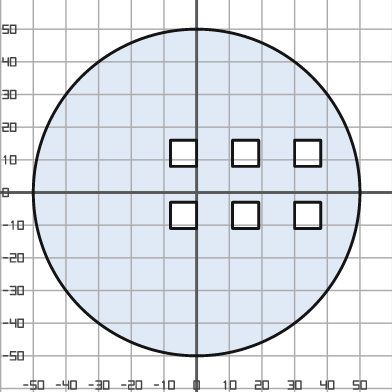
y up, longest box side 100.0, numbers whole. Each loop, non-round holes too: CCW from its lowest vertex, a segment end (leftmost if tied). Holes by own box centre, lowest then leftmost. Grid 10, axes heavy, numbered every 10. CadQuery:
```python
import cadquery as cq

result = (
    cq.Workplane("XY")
    .moveTo(0.0, 0.0)
    .circle(50.0)
    .moveTo(-8.0, -11.0)
    .lineTo(0.0, -11.0)
    .lineTo(0.0, -3.0)
    .lineTo(-8.0, -3.0)
    .close()
    .moveTo(11.0, -11.0)
    .lineTo(19.0, -11.0)
    .lineTo(19.0, -3.0)
    .lineTo(11.0, -3.0)
    .close()
    .moveTo(30.0, -11.0)
    .lineTo(38.0, -11.0)
    .lineTo(38.0, -3.0)
    .lineTo(30.0, -3.0)
    .close()
    .moveTo(-8.0, 8.0)
    .lineTo(0.0, 8.0)
    .lineTo(0.0, 16.0)
    .lineTo(-8.0, 16.0)
    .close()
    .moveTo(11.0, 8.0)
    .lineTo(19.0, 8.0)
    .lineTo(19.0, 16.0)
    .lineTo(11.0, 16.0)
    .close()
    .moveTo(30.0, 8.0)
    .lineTo(38.0, 8.0)
    .lineTo(38.0, 16.0)
    .lineTo(30.0, 16.0)
    .close()
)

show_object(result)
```